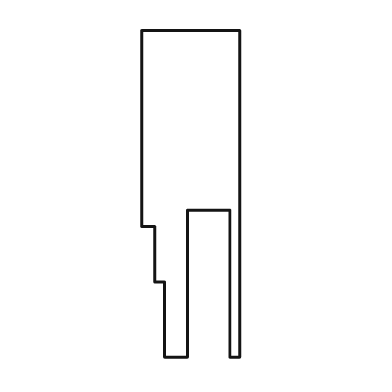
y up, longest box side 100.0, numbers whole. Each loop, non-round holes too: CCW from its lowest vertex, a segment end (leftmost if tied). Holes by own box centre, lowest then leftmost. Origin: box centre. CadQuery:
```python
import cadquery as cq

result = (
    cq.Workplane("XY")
    .moveTo(-8.0, -50.0)
    .lineTo(-1.0, -50.0)
    .lineTo(-1.0, -5.0)
    .lineTo(12.0, -5.0)
    .lineTo(12.0, -50.0)
    .lineTo(15.0, -50.0)
    .lineTo(15.0, 50.0)
    .lineTo(-15.0, 50.0)
    .lineTo(-15.0, -10.0)
    .lineTo(-11.0, -10.0)
    .lineTo(-11.0, -27.0)
    .lineTo(-8.0, -27.0)
    .close()
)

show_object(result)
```